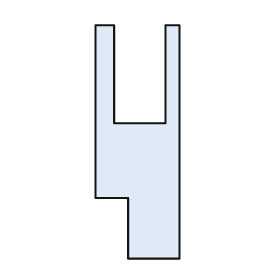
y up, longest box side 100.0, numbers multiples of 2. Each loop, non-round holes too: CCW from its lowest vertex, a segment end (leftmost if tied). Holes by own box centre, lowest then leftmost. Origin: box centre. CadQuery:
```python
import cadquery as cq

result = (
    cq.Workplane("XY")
    .moveTo(-4.0, -50.0)
    .lineTo(18.0, -50.0)
    .lineTo(18.0, 50.0)
    .lineTo(12.0, 50.0)
    .lineTo(12.0, 8.0)
    .lineTo(-10.0, 8.0)
    .lineTo(-10.0, 50.0)
    .lineTo(-18.0, 50.0)
    .lineTo(-18.0, -24.0)
    .lineTo(-4.0, -24.0)
    .close()
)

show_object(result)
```